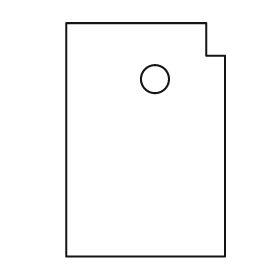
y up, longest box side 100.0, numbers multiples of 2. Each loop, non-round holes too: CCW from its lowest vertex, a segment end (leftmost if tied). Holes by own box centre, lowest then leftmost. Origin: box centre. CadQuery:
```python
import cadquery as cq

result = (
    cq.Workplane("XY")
    .moveTo(-34.0, -50.0)
    .lineTo(34.0, -50.0)
    .lineTo(34.0, 36.0)
    .lineTo(26.0, 36.0)
    .lineTo(26.0, 50.0)
    .lineTo(-34.0, 50.0)
    .close()
    .moveTo(4.0, 26.0)
    .circle(6.0)
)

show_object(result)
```